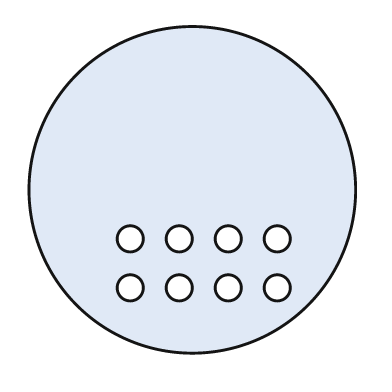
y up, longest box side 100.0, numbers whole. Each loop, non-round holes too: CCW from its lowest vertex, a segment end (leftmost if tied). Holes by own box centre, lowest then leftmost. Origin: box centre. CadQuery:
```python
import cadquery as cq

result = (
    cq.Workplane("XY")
    .moveTo(0.0, 0.0)
    .circle(50.0)
    .moveTo(-19.0, -30.0)
    .circle(4.0)
    .moveTo(-4.0, -30.0)
    .circle(4.0)
    .moveTo(11.0, -30.0)
    .circle(4.0)
    .moveTo(26.0, -30.0)
    .circle(4.0)
    .moveTo(-19.0, -15.0)
    .circle(4.0)
    .moveTo(-4.0, -15.0)
    .circle(4.0)
    .moveTo(11.0, -15.0)
    .circle(4.0)
    .moveTo(26.0, -15.0)
    .circle(4.0)
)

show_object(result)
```